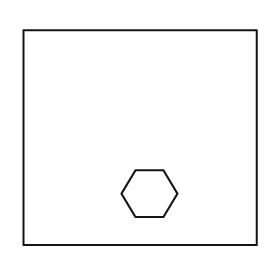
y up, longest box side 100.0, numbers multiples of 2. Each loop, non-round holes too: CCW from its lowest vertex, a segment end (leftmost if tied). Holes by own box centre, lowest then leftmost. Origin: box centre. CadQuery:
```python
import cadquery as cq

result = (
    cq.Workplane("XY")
    .moveTo(-50.0, -46.0)
    .lineTo(50.0, -46.0)
    .lineTo(50.0, 46.0)
    .lineTo(-50.0, 46.0)
    .close()
    .moveTo(-2.0, -34.0)
    .lineTo(10.0, -34.0)
    .lineTo(16.0, -24.0)
    .lineTo(10.0, -14.0)
    .lineTo(-2.0, -14.0)
    .lineTo(-8.0, -24.0)
    .close()
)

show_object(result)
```